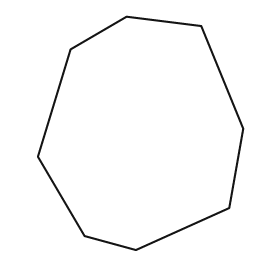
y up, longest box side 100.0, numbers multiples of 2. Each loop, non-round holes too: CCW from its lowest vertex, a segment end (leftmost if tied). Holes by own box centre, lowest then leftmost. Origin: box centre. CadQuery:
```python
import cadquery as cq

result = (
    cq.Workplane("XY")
    .moveTo(-2.0, -50.0)
    .lineTo(38.0, -32.0)
    .lineTo(44.0, 2.0)
    .lineTo(26.0, 46.0)
    .lineTo(-6.0, 50.0)
    .lineTo(-30.0, 36.0)
    .lineTo(-44.0, -10.0)
    .lineTo(-24.0, -44.0)
    .close()
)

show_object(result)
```